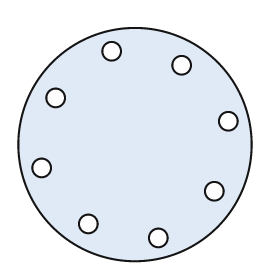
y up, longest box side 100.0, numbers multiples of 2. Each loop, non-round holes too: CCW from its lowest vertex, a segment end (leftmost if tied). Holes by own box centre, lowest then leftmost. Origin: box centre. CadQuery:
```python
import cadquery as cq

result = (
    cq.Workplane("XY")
    .moveTo(0.0, 0.0)
    .circle(50.0)
    .moveTo(10.0, -40.0)
    .circle(4.0)
    .moveTo(-20.0, -34.0)
    .circle(4.0)
    .moveTo(34.0, -20.0)
    .circle(4.0)
    .moveTo(-40.0, -10.0)
    .circle(4.0)
    .moveTo(40.0, 10.0)
    .circle(4.0)
    .moveTo(-34.0, 20.0)
    .circle(4.0)
    .moveTo(20.0, 34.0)
    .circle(4.0)
    .moveTo(-10.0, 40.0)
    .circle(4.0)
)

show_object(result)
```